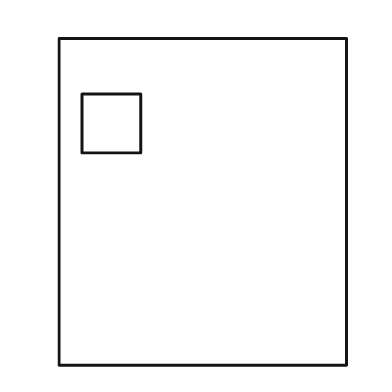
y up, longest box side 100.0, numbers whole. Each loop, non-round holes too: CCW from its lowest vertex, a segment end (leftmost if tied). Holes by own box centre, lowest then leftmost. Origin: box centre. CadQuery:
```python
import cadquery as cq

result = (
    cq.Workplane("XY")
    .moveTo(-44.0, -50.0)
    .lineTo(44.0, -50.0)
    .lineTo(44.0, 50.0)
    .lineTo(-44.0, 50.0)
    .close()
    .moveTo(-37.0, 15.0)
    .lineTo(-19.0, 15.0)
    .lineTo(-19.0, 33.0)
    .lineTo(-37.0, 33.0)
    .close()
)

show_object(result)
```